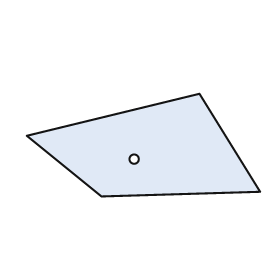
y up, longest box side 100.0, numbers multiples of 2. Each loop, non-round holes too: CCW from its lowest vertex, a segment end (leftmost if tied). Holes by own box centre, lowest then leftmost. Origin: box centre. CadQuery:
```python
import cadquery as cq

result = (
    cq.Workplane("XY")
    .moveTo(-18.0, -22.0)
    .lineTo(50.0, -20.0)
    .lineTo(24.0, 22.0)
    .lineTo(-50.0, 4.0)
    .close()
    .moveTo(-4.0, -6.0)
    .circle(2.0)
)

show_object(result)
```